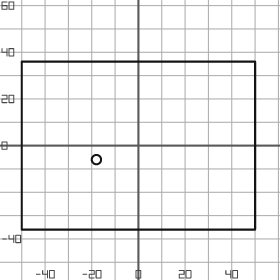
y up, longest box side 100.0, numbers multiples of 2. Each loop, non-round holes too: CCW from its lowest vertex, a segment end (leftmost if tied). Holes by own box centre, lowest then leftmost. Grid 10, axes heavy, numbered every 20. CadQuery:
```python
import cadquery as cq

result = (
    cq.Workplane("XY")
    .moveTo(-50.0, -36.0)
    .lineTo(50.0, -36.0)
    .lineTo(50.0, 36.0)
    .lineTo(-50.0, 36.0)
    .close()
    .moveTo(-18.0, -6.0)
    .circle(2.0)
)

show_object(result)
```